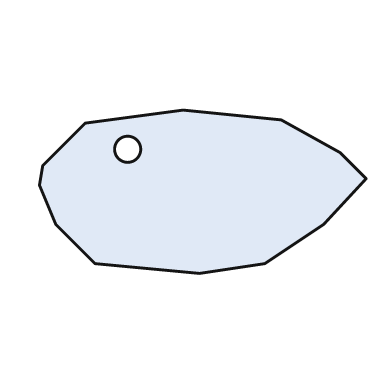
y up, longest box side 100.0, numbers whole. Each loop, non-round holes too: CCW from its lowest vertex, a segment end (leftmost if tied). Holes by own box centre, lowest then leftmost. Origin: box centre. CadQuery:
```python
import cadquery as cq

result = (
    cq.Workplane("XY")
    .moveTo(-1.0, -25.0)
    .lineTo(19.0, -22.0)
    .lineTo(37.0, -10.0)
    .lineTo(50.0, 4.0)
    .lineTo(42.0, 12.0)
    .lineTo(24.0, 22.0)
    .lineTo(-6.0, 25.0)
    .lineTo(-36.0, 21.0)
    .lineTo(-49.0, 8.0)
    .lineTo(-50.0, 2.0)
    .lineTo(-45.0, -10.0)
    .lineTo(-33.0, -22.0)
    .close()
    .moveTo(-23.0, 13.0)
    .circle(4.0)
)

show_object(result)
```